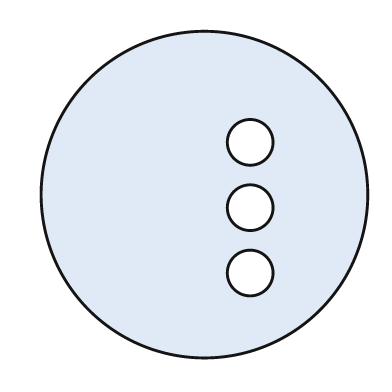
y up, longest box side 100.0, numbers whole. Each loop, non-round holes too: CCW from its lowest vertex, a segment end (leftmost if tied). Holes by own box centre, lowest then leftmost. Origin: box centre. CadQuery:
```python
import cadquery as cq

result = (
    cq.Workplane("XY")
    .moveTo(0.0, 0.0)
    .circle(50.0)
    .moveTo(14.0, -24.0)
    .circle(7.0)
    .moveTo(14.0, -4.0)
    .circle(7.0)
    .moveTo(14.0, 16.0)
    .circle(7.0)
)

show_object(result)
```